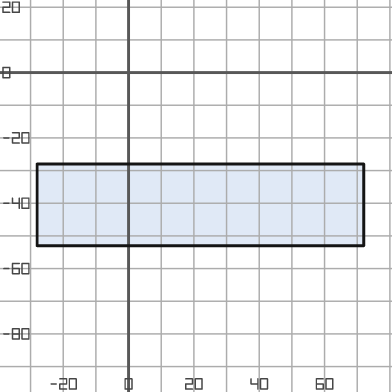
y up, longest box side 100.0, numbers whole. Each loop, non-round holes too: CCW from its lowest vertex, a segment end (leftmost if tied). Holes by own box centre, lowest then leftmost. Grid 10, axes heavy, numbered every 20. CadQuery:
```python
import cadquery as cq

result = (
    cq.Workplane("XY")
    .moveTo(-28.0, -53.0)
    .lineTo(72.0, -53.0)
    .lineTo(72.0, -28.0)
    .lineTo(-28.0, -28.0)
    .close()
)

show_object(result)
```